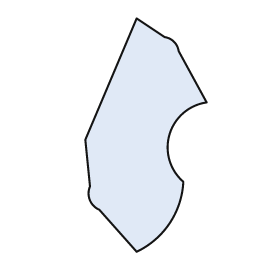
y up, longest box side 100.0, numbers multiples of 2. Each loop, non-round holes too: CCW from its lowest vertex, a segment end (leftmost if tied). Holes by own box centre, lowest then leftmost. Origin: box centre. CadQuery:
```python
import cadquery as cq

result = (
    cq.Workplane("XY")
    .moveTo(-4.0, -50.0)
    .threePointArc((10.0, -38.0), (16.0, -20.0))
    .threePointArc((10.0, 0.0), (26.0, 14.0))
    .lineTo(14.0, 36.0)
    .threePointArc((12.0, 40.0), (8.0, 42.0))
    .lineTo(-4.0, 50.0)
    .lineTo(-26.0, -2.0)
    .lineTo(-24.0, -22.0)
    .threePointArc((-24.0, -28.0), (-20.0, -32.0))
    .close()
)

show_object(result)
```